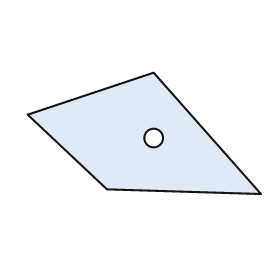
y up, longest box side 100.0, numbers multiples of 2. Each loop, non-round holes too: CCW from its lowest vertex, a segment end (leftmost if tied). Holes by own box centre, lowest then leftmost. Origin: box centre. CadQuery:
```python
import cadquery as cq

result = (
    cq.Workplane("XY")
    .moveTo(50.0, -26.0)
    .lineTo(4.0, 26.0)
    .lineTo(-50.0, 8.0)
    .lineTo(-16.0, -24.0)
    .close()
    .moveTo(4.0, -2.0)
    .circle(4.0)
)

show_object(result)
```